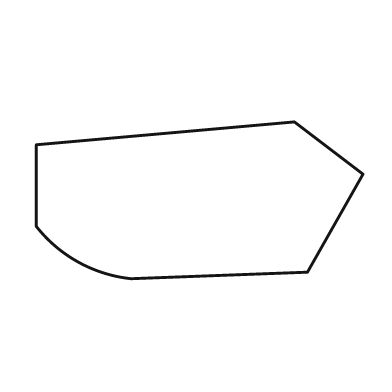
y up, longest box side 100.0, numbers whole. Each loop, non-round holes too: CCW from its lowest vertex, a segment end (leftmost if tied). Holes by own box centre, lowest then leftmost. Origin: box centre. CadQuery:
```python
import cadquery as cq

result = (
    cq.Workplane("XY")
    .moveTo(-21.0, -24.0)
    .lineTo(33.0, -22.0)
    .lineTo(50.0, 8.0)
    .lineTo(29.0, 24.0)
    .lineTo(-50.0, 17.0)
    .lineTo(-50.0, -8.0)
    .threePointArc((-37.0, -19.0), (-21.0, -24.0))
    .close()
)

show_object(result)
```